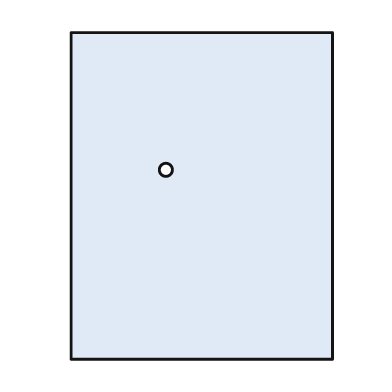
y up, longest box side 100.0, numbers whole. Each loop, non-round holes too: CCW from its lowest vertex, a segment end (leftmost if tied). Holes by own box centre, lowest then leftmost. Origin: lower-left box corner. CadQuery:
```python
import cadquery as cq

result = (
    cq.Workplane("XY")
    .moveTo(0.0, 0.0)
    .lineTo(80.0, 0.0)
    .lineTo(80.0, 100.0)
    .lineTo(0.0, 100.0)
    .close()
    .moveTo(29.0, 58.0)
    .circle(2.0)
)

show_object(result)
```